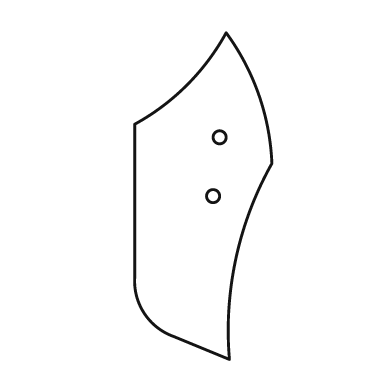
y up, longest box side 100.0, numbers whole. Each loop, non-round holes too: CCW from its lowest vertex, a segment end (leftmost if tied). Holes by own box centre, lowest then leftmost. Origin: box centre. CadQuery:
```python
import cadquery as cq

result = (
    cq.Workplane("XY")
    .moveTo(8.0, -50.0)
    .threePointArc((10.0, -19.0), (21.0, 10.0))
    .threePointArc((17.0, 31.0), (7.0, 50.0))
    .threePointArc((-5.0, 34.0), (-21.0, 22.0))
    .lineTo(-21.0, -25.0)
    .threePointArc((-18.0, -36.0), (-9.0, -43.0))
    .close()
    .moveTo(3.0, 0.0)
    .circle(2.0)
    .moveTo(5.0, 18.0)
    .circle(2.0)
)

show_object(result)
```